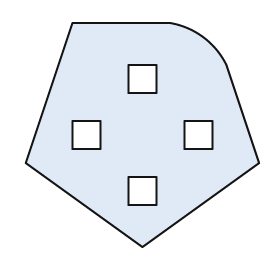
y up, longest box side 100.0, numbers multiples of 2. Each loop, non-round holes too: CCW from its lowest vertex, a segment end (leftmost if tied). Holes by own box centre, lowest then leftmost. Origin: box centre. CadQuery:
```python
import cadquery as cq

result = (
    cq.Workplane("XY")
    .moveTo(0.0, -48.0)
    .lineTo(50.0, -12.0)
    .lineTo(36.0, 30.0)
    .threePointArc((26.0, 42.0), (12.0, 48.0))
    .lineTo(-30.0, 48.0)
    .lineTo(-50.0, -12.0)
    .close()
    .moveTo(-6.0, -30.0)
    .lineTo(6.0, -30.0)
    .lineTo(6.0, -18.0)
    .lineTo(-6.0, -18.0)
    .close()
    .moveTo(-30.0, -6.0)
    .lineTo(-18.0, -6.0)
    .lineTo(-18.0, 6.0)
    .lineTo(-30.0, 6.0)
    .close()
    .moveTo(18.0, -6.0)
    .lineTo(30.0, -6.0)
    .lineTo(30.0, 6.0)
    .lineTo(18.0, 6.0)
    .close()
    .moveTo(-6.0, 18.0)
    .lineTo(6.0, 18.0)
    .lineTo(6.0, 30.0)
    .lineTo(-6.0, 30.0)
    .close()
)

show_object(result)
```